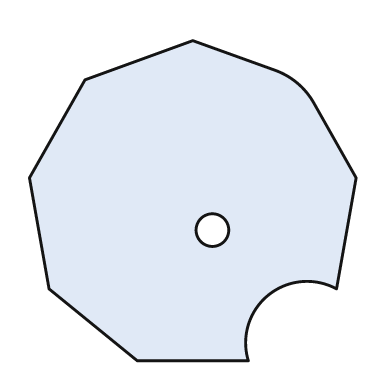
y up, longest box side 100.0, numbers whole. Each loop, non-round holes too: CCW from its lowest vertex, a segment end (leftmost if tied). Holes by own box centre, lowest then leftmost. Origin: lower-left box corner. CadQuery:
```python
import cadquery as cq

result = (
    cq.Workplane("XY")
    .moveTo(33.0, 0.0)
    .lineTo(67.0, 0.0)
    .threePointArc((73.0, 20.0), (94.0, 22.0))
    .lineTo(100.0, 56.0)
    .lineTo(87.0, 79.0)
    .threePointArc((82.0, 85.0), (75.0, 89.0))
    .lineTo(50.0, 98.0)
    .lineTo(17.0, 86.0)
    .lineTo(0.0, 56.0)
    .lineTo(6.0, 22.0)
    .close()
    .moveTo(56.0, 40.0)
    .circle(5.0)
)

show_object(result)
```